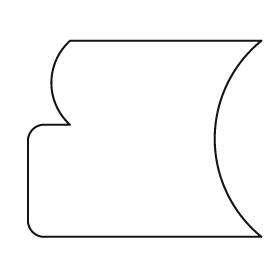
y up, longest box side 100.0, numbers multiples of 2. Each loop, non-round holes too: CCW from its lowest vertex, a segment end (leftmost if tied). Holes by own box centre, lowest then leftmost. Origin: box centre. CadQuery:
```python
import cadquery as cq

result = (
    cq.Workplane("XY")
    .moveTo(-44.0, -42.0)
    .lineTo(50.0, -42.0)
    .threePointArc((30.0, 0.0), (50.0, 42.0))
    .lineTo(-32.0, 42.0)
    .threePointArc((-40.0, 24.0), (-32.0, 6.0))
    .lineTo(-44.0, 6.0)
    .threePointArc((-48.0, 4.0), (-50.0, 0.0))
    .lineTo(-50.0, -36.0)
    .threePointArc((-48.0, -40.0), (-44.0, -42.0))
    .close()
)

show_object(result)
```